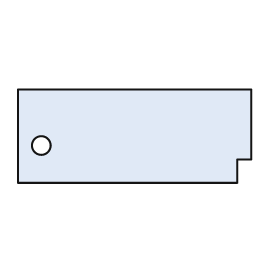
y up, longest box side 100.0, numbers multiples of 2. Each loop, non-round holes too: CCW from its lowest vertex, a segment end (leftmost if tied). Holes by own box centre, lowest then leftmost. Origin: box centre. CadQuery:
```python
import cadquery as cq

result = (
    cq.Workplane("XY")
    .moveTo(-50.0, -20.0)
    .lineTo(44.0, -20.0)
    .lineTo(44.0, -10.0)
    .lineTo(50.0, -10.0)
    .lineTo(50.0, 20.0)
    .lineTo(-50.0, 20.0)
    .close()
    .moveTo(-40.0, -4.0)
    .circle(4.0)
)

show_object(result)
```